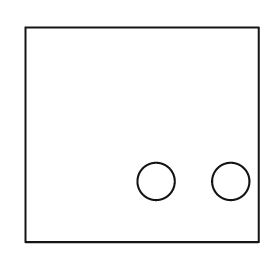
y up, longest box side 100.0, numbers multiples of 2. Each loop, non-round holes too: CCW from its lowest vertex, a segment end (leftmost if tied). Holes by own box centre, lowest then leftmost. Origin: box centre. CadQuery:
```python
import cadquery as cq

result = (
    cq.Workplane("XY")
    .moveTo(-50.0, -46.0)
    .lineTo(50.0, -46.0)
    .lineTo(50.0, 46.0)
    .lineTo(-50.0, 46.0)
    .close()
    .moveTo(6.0, -20.0)
    .circle(8.0)
    .moveTo(38.0, -20.0)
    .circle(8.0)
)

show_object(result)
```